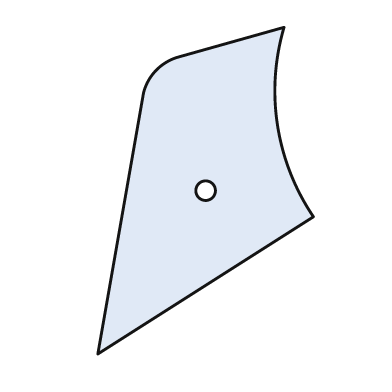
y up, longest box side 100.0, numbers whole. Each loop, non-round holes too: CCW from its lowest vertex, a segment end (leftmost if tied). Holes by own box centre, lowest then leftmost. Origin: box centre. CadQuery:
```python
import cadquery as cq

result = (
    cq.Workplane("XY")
    .moveTo(-33.0, -50.0)
    .lineTo(33.0, -8.0)
    .threePointArc((22.0, 20.0), (24.0, 50.0))
    .lineTo(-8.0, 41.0)
    .threePointArc((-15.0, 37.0), (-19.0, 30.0))
    .close()
    .moveTo(0.0, 0.0)
    .circle(3.0)
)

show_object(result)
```